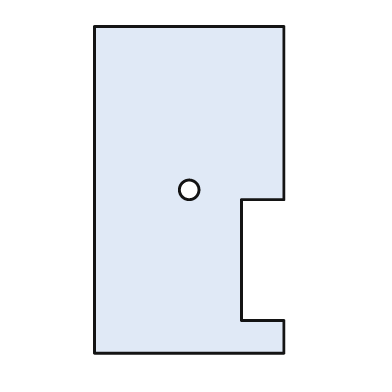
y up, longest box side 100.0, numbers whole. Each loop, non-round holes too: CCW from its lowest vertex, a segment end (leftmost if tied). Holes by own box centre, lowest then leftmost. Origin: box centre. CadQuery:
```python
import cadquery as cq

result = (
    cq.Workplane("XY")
    .moveTo(-29.0, -50.0)
    .lineTo(29.0, -50.0)
    .lineTo(29.0, -40.0)
    .lineTo(16.0, -40.0)
    .lineTo(16.0, -3.0)
    .lineTo(29.0, -3.0)
    .lineTo(29.0, 50.0)
    .lineTo(-29.0, 50.0)
    .close()
    .moveTo(0.0, 0.0)
    .circle(3.0)
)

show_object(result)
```